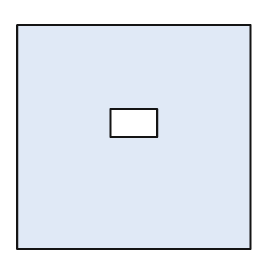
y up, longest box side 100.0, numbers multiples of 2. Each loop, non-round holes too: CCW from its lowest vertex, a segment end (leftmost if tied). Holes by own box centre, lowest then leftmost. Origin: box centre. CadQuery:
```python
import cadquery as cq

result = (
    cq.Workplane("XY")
    .moveTo(-50.0, -48.0)
    .lineTo(50.0, -48.0)
    .lineTo(50.0, 48.0)
    .lineTo(-50.0, 48.0)
    .close()
    .moveTo(-10.0, 0.0)
    .lineTo(10.0, 0.0)
    .lineTo(10.0, 12.0)
    .lineTo(-10.0, 12.0)
    .close()
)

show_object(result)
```